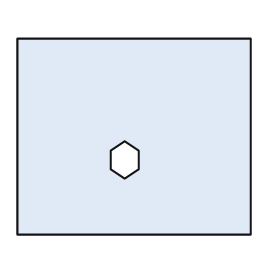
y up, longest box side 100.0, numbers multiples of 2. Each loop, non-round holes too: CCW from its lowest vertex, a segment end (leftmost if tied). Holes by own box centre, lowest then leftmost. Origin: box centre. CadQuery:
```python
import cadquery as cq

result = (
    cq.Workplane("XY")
    .moveTo(-50.0, -42.0)
    .lineTo(50.0, -42.0)
    .lineTo(50.0, 42.0)
    .lineTo(-50.0, 42.0)
    .close()
    .moveTo(-4.0, -18.0)
    .lineTo(2.0, -14.0)
    .lineTo(2.0, -6.0)
    .lineTo(-4.0, -2.0)
    .lineTo(-10.0, -6.0)
    .lineTo(-10.0, -14.0)
    .close()
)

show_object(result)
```